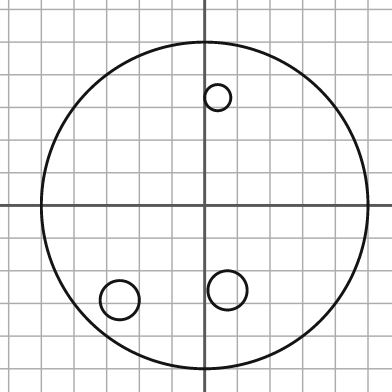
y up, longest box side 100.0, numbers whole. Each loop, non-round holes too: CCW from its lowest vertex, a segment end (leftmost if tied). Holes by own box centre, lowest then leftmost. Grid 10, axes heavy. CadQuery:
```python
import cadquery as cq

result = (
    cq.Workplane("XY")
    .moveTo(0.0, 0.0)
    .circle(50.0)
    .moveTo(-26.0, -29.0)
    .circle(6.0)
    .moveTo(7.0, -26.0)
    .circle(6.0)
    .moveTo(4.0, 33.0)
    .circle(4.0)
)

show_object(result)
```